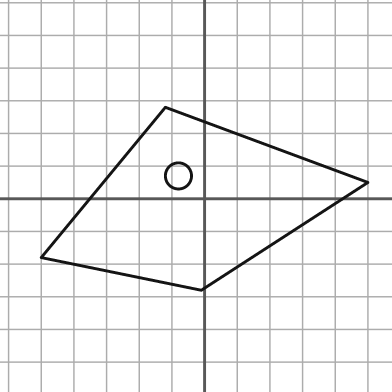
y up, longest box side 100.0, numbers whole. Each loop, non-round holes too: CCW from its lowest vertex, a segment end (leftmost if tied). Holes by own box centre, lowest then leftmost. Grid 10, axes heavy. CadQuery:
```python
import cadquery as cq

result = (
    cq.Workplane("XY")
    .moveTo(-1.0, -28.0)
    .lineTo(50.0, 5.0)
    .lineTo(-12.0, 28.0)
    .lineTo(-50.0, -18.0)
    .close()
    .moveTo(-8.0, 7.0)
    .circle(4.0)
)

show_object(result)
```